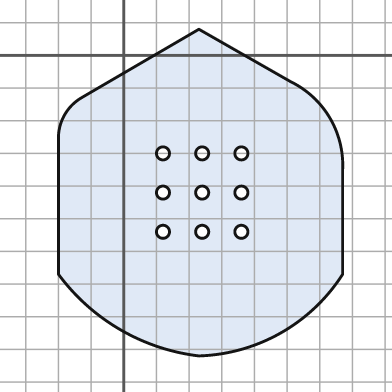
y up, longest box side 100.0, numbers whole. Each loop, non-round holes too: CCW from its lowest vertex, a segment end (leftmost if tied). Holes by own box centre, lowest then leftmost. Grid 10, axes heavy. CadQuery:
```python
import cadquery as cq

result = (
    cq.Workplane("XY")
    .moveTo(23.0, -92.0)
    .threePointArc((48.0, -85.0), (67.0, -67.0))
    .lineTo(67.0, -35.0)
    .threePointArc((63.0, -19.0), (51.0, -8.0))
    .lineTo(23.0, 8.0)
    .lineTo(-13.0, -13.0)
    .threePointArc((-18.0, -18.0), (-20.0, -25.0))
    .lineTo(-20.0, -67.0)
    .threePointArc((-1.0, -84.0), (23.0, -92.0))
    .close()
    .moveTo(12.0, -54.0)
    .circle(2.0)
    .moveTo(24.0, -54.0)
    .circle(2.0)
    .moveTo(36.0, -54.0)
    .circle(2.0)
    .moveTo(12.0, -42.0)
    .circle(2.0)
    .moveTo(24.0, -42.0)
    .circle(2.0)
    .moveTo(36.0, -42.0)
    .circle(2.0)
    .moveTo(12.0, -30.0)
    .circle(2.0)
    .moveTo(24.0, -30.0)
    .circle(2.0)
    .moveTo(36.0, -30.0)
    .circle(2.0)
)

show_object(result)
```